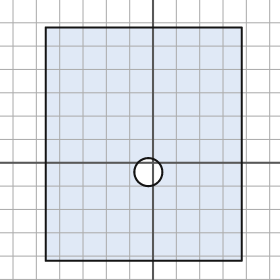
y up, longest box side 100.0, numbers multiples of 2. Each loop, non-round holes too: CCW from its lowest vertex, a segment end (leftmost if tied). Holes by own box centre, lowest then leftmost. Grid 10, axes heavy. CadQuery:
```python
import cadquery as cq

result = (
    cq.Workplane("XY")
    .moveTo(-46.0, -42.0)
    .lineTo(38.0, -42.0)
    .lineTo(38.0, 58.0)
    .lineTo(-46.0, 58.0)
    .close()
    .moveTo(-2.0, -4.0)
    .circle(6.0)
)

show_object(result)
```